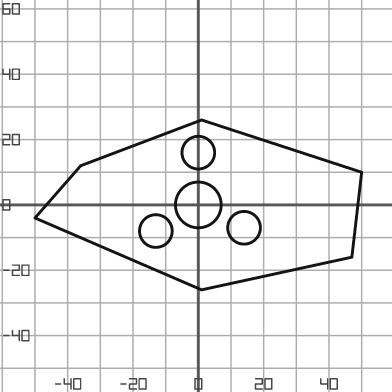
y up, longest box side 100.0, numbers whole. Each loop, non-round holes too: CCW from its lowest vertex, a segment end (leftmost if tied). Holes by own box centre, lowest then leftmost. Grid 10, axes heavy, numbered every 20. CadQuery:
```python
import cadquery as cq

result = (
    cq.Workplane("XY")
    .moveTo(1.0, -26.0)
    .lineTo(47.0, -16.0)
    .lineTo(50.0, 10.0)
    .lineTo(1.0, 26.0)
    .lineTo(-36.0, 12.0)
    .lineTo(-50.0, -4.0)
    .close()
    .moveTo(-13.0, -8.0)
    .circle(5.0)
    .moveTo(14.0, -7.0)
    .circle(5.0)
    .moveTo(0.0, 0.0)
    .circle(7.0)
    .moveTo(0.0, 16.0)
    .circle(5.0)
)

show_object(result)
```